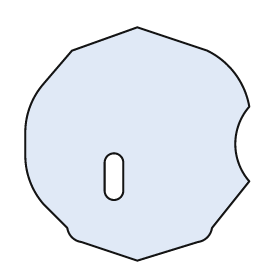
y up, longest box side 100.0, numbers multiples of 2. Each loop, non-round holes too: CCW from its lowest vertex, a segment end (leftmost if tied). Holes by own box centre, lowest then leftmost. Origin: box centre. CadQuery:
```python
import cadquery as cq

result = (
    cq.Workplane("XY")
    .moveTo(0.0, -50.0)
    .lineTo(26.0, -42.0)
    .threePointArc((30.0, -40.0), (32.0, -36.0))
    .lineTo(48.0, -16.0)
    .threePointArc((42.0, 0.0), (48.0, 16.0))
    .threePointArc((42.0, 30.0), (30.0, 40.0))
    .lineTo(0.0, 50.0)
    .lineTo(-28.0, 40.0)
    .lineTo(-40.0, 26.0)
    .threePointArc((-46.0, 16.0), (-48.0, 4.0))
    .lineTo(-48.0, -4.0)
    .threePointArc((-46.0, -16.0), (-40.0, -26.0))
    .lineTo(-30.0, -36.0)
    .threePointArc((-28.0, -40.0), (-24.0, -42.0))
    .close()
    .moveTo(-14.0, -20.0)
    .threePointArc((-10.0, -24.0), (-6.0, -20.0))
    .lineTo(-6.0, -8.0)
    .threePointArc((-10.0, -4.0), (-14.0, -8.0))
    .close()
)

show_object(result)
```